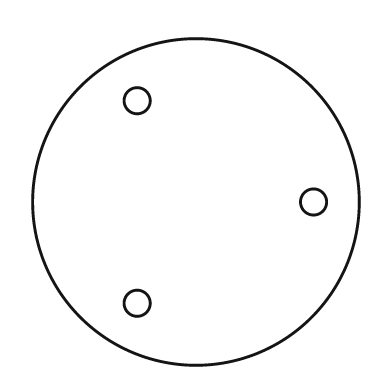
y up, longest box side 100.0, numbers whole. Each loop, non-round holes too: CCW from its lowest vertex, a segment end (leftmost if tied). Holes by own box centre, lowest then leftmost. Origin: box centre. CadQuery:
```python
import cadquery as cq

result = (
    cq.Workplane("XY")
    .moveTo(0.0, 0.0)
    .circle(50.0)
    .moveTo(-18.0, -31.0)
    .circle(4.0)
    .moveTo(36.0, 0.0)
    .circle(4.0)
    .moveTo(-18.0, 31.0)
    .circle(4.0)
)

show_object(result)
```